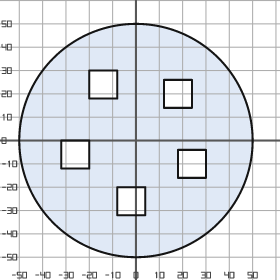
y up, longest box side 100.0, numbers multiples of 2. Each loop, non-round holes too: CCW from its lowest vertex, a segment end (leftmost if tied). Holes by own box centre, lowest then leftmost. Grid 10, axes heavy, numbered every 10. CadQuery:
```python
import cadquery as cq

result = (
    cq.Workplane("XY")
    .moveTo(0.0, 0.0)
    .circle(50.0)
    .moveTo(-8.0, -32.0)
    .lineTo(4.0, -32.0)
    .lineTo(4.0, -20.0)
    .lineTo(-8.0, -20.0)
    .close()
    .moveTo(18.0, -16.0)
    .lineTo(30.0, -16.0)
    .lineTo(30.0, -4.0)
    .lineTo(18.0, -4.0)
    .close()
    .moveTo(-32.0, -12.0)
    .lineTo(-20.0, -12.0)
    .lineTo(-20.0, 0.0)
    .lineTo(-32.0, 0.0)
    .close()
    .moveTo(12.0, 14.0)
    .lineTo(24.0, 14.0)
    .lineTo(24.0, 26.0)
    .lineTo(12.0, 26.0)
    .close()
    .moveTo(-20.0, 18.0)
    .lineTo(-8.0, 18.0)
    .lineTo(-8.0, 30.0)
    .lineTo(-20.0, 30.0)
    .close()
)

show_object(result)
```